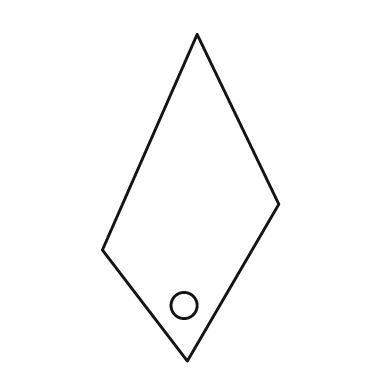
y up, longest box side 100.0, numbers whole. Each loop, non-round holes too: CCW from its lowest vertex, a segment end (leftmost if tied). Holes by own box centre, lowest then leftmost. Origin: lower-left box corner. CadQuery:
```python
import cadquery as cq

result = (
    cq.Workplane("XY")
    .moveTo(26.0, 0.0)
    .lineTo(54.0, 48.0)
    .lineTo(29.0, 100.0)
    .lineTo(0.0, 34.0)
    .close()
    .moveTo(25.0, 17.0)
    .circle(4.0)
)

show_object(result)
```